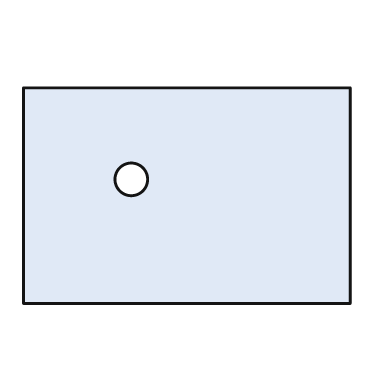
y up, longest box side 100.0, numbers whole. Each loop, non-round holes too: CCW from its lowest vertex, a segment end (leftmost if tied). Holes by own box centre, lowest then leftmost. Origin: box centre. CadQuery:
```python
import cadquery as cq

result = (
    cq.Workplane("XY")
    .moveTo(-50.0, -33.0)
    .lineTo(50.0, -33.0)
    .lineTo(50.0, 33.0)
    .lineTo(-50.0, 33.0)
    .close()
    .moveTo(-17.0, 5.0)
    .circle(5.0)
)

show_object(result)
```